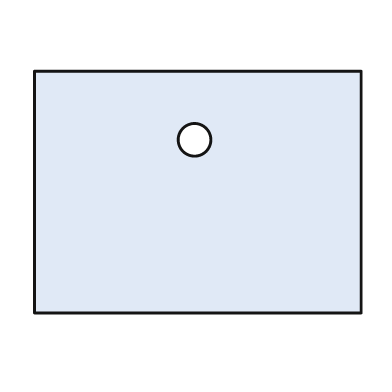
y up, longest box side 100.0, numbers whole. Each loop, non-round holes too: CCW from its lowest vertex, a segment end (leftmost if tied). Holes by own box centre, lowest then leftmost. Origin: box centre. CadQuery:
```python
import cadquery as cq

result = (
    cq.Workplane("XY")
    .moveTo(-50.0, -37.0)
    .lineTo(50.0, -37.0)
    .lineTo(50.0, 37.0)
    .lineTo(-50.0, 37.0)
    .close()
    .moveTo(-1.0, 16.0)
    .circle(5.0)
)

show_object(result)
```